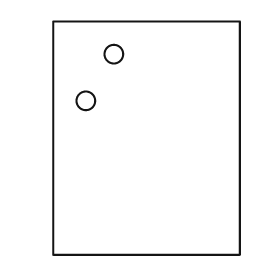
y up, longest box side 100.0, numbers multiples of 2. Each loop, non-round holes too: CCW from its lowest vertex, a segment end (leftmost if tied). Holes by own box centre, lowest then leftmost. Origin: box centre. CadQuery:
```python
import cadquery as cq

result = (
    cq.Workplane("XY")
    .moveTo(-40.0, -50.0)
    .lineTo(40.0, -50.0)
    .lineTo(40.0, 50.0)
    .lineTo(-40.0, 50.0)
    .close()
    .moveTo(-26.0, 16.0)
    .circle(4.0)
    .moveTo(-14.0, 36.0)
    .circle(4.0)
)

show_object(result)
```